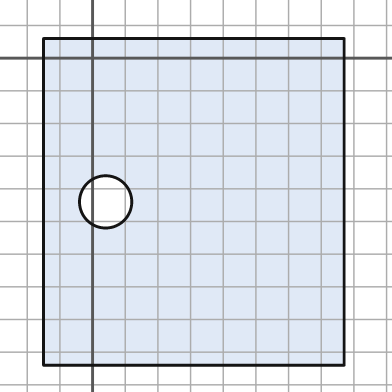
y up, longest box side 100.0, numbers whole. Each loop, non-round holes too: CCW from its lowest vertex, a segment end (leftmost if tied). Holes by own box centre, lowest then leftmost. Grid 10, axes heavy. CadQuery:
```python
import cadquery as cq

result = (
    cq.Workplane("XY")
    .moveTo(-15.0, -94.0)
    .lineTo(77.0, -94.0)
    .lineTo(77.0, 6.0)
    .lineTo(-15.0, 6.0)
    .close()
    .moveTo(4.0, -44.0)
    .circle(8.0)
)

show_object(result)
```